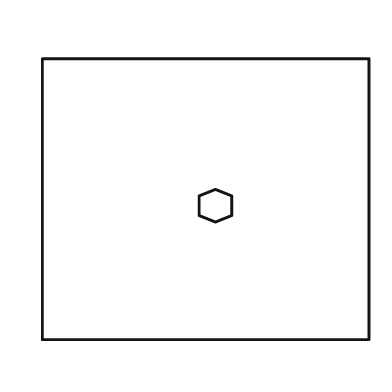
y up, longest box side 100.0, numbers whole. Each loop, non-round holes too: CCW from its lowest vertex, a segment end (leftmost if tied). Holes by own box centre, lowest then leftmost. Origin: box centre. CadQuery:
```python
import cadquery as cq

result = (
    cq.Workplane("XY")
    .moveTo(-50.0, -43.0)
    .lineTo(50.0, -43.0)
    .lineTo(50.0, 43.0)
    .lineTo(-50.0, 43.0)
    .close()
    .moveTo(3.0, -7.0)
    .lineTo(8.0, -5.0)
    .lineTo(8.0, 1.0)
    .lineTo(3.0, 3.0)
    .lineTo(-2.0, 1.0)
    .lineTo(-2.0, -5.0)
    .close()
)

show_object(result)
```